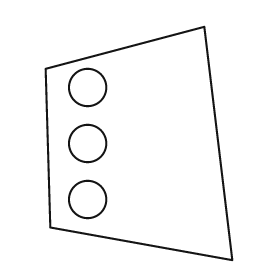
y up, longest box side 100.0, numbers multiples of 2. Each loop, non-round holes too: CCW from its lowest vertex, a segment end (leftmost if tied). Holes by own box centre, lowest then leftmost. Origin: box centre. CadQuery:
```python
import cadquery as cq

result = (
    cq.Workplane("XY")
    .moveTo(40.0, -50.0)
    .lineTo(28.0, 50.0)
    .lineTo(-40.0, 32.0)
    .lineTo(-38.0, -36.0)
    .close()
    .moveTo(-22.0, -24.0)
    .circle(8.0)
    .moveTo(-22.0, 0.0)
    .circle(8.0)
    .moveTo(-22.0, 24.0)
    .circle(8.0)
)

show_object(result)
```